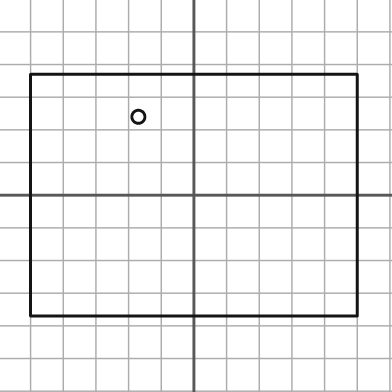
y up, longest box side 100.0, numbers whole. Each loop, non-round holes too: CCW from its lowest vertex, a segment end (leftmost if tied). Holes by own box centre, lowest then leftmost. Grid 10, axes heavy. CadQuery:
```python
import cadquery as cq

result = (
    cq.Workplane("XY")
    .moveTo(-50.0, -37.0)
    .lineTo(50.0, -37.0)
    .lineTo(50.0, 37.0)
    .lineTo(-50.0, 37.0)
    .close()
    .moveTo(-17.0, 24.0)
    .circle(2.0)
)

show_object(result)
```